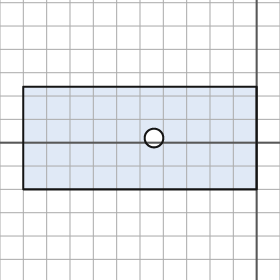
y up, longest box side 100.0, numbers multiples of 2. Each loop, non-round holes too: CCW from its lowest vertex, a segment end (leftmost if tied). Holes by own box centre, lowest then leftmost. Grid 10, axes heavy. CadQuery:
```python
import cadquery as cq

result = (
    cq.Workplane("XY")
    .moveTo(-100.0, -20.0)
    .lineTo(0.0, -20.0)
    .lineTo(0.0, 24.0)
    .lineTo(-100.0, 24.0)
    .close()
    .moveTo(-44.0, 2.0)
    .circle(4.0)
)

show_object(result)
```